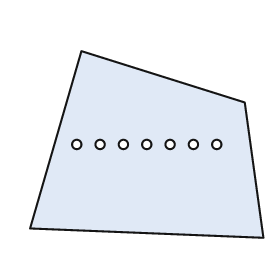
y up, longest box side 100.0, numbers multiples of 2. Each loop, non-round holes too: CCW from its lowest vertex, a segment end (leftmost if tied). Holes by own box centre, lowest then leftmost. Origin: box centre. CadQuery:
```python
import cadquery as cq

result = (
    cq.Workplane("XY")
    .moveTo(50.0, -40.0)
    .lineTo(42.0, 18.0)
    .lineTo(-28.0, 40.0)
    .lineTo(-50.0, -36.0)
    .close()
    .moveTo(-30.0, 0.0)
    .circle(2.0)
    .moveTo(-20.0, 0.0)
    .circle(2.0)
    .moveTo(-10.0, 0.0)
    .circle(2.0)
    .moveTo(0.0, 0.0)
    .circle(2.0)
    .moveTo(10.0, 0.0)
    .circle(2.0)
    .moveTo(20.0, 0.0)
    .circle(2.0)
    .moveTo(30.0, 0.0)
    .circle(2.0)
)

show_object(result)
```